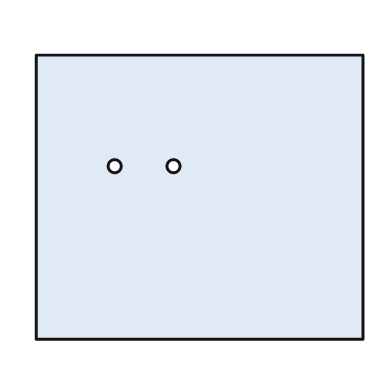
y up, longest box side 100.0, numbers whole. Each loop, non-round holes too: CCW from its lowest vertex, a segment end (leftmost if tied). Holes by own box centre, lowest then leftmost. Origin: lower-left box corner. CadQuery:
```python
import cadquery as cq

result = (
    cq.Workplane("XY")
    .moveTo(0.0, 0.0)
    .lineTo(100.0, 0.0)
    .lineTo(100.0, 87.0)
    .lineTo(0.0, 87.0)
    .close()
    .moveTo(24.0, 53.0)
    .circle(2.0)
    .moveTo(42.0, 53.0)
    .circle(2.0)
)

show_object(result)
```